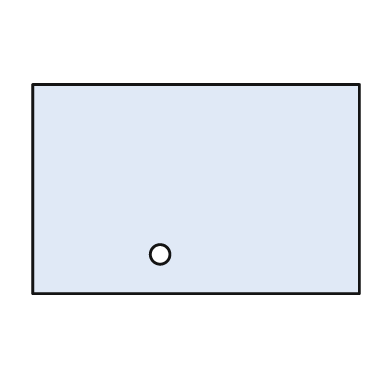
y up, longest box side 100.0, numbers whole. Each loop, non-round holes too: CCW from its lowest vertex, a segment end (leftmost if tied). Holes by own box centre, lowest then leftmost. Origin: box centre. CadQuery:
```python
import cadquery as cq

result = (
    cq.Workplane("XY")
    .moveTo(-50.0, -32.0)
    .lineTo(50.0, -32.0)
    .lineTo(50.0, 32.0)
    .lineTo(-50.0, 32.0)
    .close()
    .moveTo(-11.0, -20.0)
    .circle(3.0)
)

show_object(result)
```